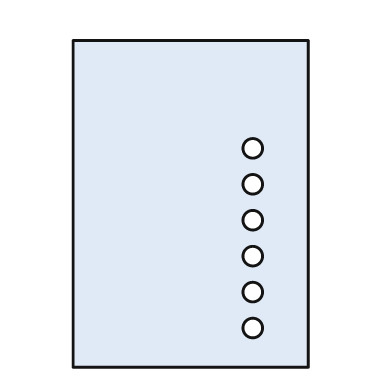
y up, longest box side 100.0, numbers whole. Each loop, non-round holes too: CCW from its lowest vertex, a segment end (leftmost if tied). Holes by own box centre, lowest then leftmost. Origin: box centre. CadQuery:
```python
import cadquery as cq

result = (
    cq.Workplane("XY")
    .moveTo(-36.0, -50.0)
    .lineTo(36.0, -50.0)
    .lineTo(36.0, 50.0)
    .lineTo(-36.0, 50.0)
    .close()
    .moveTo(19.0, -38.0)
    .circle(3.0)
    .moveTo(19.0, -27.0)
    .circle(3.0)
    .moveTo(19.0, -16.0)
    .circle(3.0)
    .moveTo(19.0, -5.0)
    .circle(3.0)
    .moveTo(19.0, 6.0)
    .circle(3.0)
    .moveTo(19.0, 17.0)
    .circle(3.0)
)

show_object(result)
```